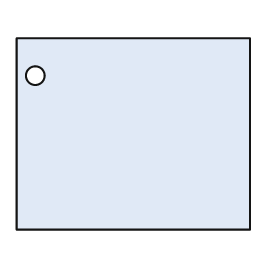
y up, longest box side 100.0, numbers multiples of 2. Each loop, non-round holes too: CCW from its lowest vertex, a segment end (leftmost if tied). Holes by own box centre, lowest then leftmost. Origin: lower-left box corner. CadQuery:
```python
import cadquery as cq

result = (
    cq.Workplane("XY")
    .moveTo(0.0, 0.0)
    .lineTo(100.0, 0.0)
    .lineTo(100.0, 82.0)
    .lineTo(0.0, 82.0)
    .close()
    .moveTo(8.0, 66.0)
    .circle(4.0)
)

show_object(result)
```